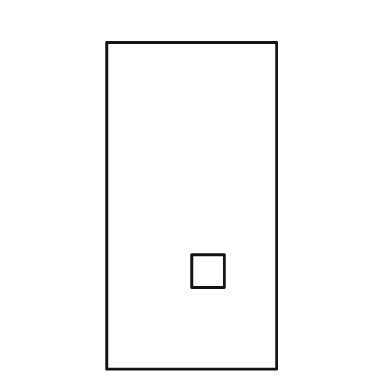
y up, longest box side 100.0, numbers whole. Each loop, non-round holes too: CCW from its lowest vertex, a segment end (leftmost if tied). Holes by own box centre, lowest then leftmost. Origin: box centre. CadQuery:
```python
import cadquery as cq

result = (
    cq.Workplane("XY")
    .moveTo(-26.0, -50.0)
    .lineTo(26.0, -50.0)
    .lineTo(26.0, 50.0)
    .lineTo(-26.0, 50.0)
    .close()
    .moveTo(0.0, -25.0)
    .lineTo(10.0, -25.0)
    .lineTo(10.0, -15.0)
    .lineTo(0.0, -15.0)
    .close()
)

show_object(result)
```